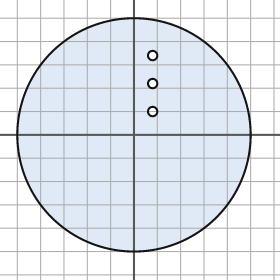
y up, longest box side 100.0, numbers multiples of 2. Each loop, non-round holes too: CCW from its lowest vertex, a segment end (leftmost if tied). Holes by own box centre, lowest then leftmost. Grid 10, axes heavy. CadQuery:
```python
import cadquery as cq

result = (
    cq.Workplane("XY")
    .moveTo(0.0, 0.0)
    .circle(50.0)
    .moveTo(8.0, 10.0)
    .circle(2.0)
    .moveTo(8.0, 22.0)
    .circle(2.0)
    .moveTo(8.0, 34.0)
    .circle(2.0)
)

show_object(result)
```